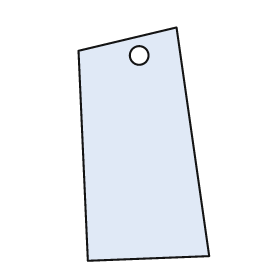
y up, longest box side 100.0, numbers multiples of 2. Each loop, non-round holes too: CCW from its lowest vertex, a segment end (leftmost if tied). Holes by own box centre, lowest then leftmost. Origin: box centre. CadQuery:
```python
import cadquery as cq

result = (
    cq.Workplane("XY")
    .moveTo(-24.0, -50.0)
    .lineTo(28.0, -48.0)
    .lineTo(14.0, 50.0)
    .lineTo(-28.0, 40.0)
    .close()
    .moveTo(-2.0, 38.0)
    .circle(4.0)
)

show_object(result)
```